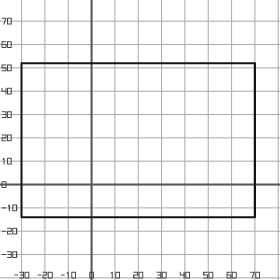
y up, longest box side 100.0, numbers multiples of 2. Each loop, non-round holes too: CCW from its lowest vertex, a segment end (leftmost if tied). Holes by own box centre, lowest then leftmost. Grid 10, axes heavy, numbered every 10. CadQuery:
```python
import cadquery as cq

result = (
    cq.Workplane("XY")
    .moveTo(-30.0, -14.0)
    .lineTo(70.0, -14.0)
    .lineTo(70.0, 52.0)
    .lineTo(-30.0, 52.0)
    .close()
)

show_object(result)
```